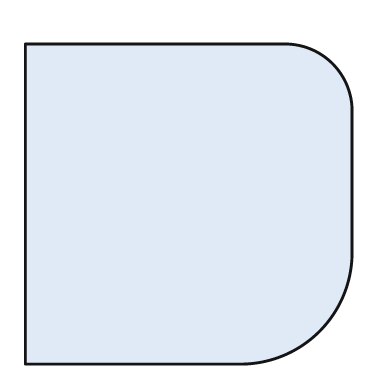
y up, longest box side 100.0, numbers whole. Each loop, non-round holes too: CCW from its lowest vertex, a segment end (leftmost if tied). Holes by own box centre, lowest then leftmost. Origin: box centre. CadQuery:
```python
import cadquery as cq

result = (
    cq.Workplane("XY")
    .moveTo(-50.0, -49.0)
    .lineTo(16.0, -49.0)
    .threePointArc((40.0, -39.0), (50.0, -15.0))
    .lineTo(50.0, 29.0)
    .threePointArc((44.0, 43.0), (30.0, 49.0))
    .lineTo(-50.0, 49.0)
    .close()
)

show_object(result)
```